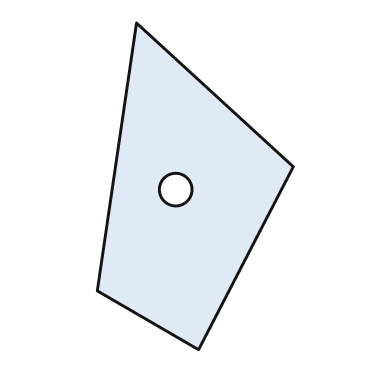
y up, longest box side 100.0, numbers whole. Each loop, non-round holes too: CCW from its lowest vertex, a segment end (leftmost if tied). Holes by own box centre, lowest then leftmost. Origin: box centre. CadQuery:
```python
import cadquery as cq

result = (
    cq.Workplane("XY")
    .moveTo(1.0, -50.0)
    .lineTo(30.0, 6.0)
    .lineTo(-18.0, 50.0)
    .lineTo(-30.0, -32.0)
    .close()
    .moveTo(-6.0, -1.0)
    .circle(5.0)
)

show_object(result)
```